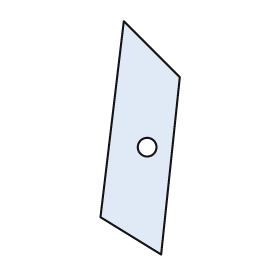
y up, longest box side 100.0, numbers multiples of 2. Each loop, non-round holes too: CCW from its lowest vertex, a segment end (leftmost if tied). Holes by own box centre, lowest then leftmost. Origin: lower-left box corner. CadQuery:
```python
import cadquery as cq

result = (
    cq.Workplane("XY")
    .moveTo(26.0, 0.0)
    .lineTo(34.0, 76.0)
    .lineTo(10.0, 100.0)
    .lineTo(0.0, 16.0)
    .close()
    .moveTo(20.0, 46.0)
    .circle(4.0)
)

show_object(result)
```